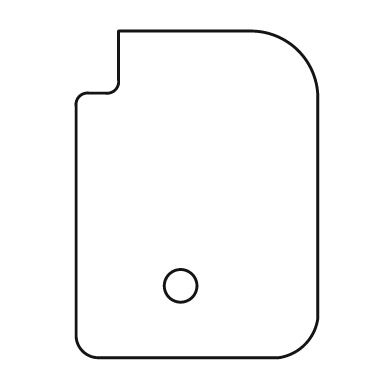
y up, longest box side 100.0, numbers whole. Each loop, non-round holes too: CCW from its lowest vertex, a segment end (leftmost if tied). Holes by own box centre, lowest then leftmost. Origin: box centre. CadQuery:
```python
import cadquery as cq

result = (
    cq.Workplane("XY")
    .moveTo(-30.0, -50.0)
    .lineTo(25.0, -50.0)
    .threePointArc((33.0, -46.0), (37.0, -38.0))
    .lineTo(37.0, 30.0)
    .threePointArc((31.0, 44.0), (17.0, 50.0))
    .lineTo(-24.0, 50.0)
    .lineTo(-24.0, 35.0)
    .threePointArc((-25.0, 32.0), (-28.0, 31.0))
    .lineTo(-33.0, 31.0)
    .threePointArc((-36.0, 30.0), (-37.0, 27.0))
    .lineTo(-37.0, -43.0)
    .threePointArc((-35.0, -48.0), (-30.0, -50.0))
    .close()
    .moveTo(-5.0, -28.0)
    .circle(5.0)
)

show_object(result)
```